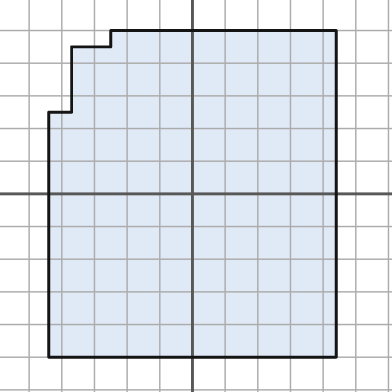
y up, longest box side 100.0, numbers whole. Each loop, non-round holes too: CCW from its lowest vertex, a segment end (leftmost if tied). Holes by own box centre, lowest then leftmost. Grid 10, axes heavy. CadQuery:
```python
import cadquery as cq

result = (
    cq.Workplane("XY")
    .moveTo(-44.0, -50.0)
    .lineTo(44.0, -50.0)
    .lineTo(44.0, 50.0)
    .lineTo(-25.0, 50.0)
    .lineTo(-25.0, 45.0)
    .lineTo(-37.0, 45.0)
    .lineTo(-37.0, 25.0)
    .lineTo(-44.0, 25.0)
    .close()
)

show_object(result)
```